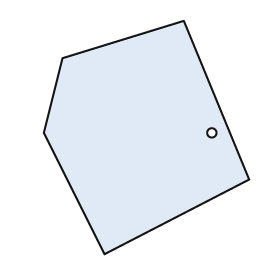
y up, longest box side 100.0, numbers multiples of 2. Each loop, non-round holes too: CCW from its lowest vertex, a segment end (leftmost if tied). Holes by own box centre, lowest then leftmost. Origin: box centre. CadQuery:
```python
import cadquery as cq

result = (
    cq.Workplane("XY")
    .moveTo(-18.0, -50.0)
    .lineTo(44.0, -18.0)
    .lineTo(16.0, 50.0)
    .lineTo(-36.0, 34.0)
    .lineTo(-44.0, 2.0)
    .close()
    .moveTo(28.0, 2.0)
    .circle(2.0)
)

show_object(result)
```